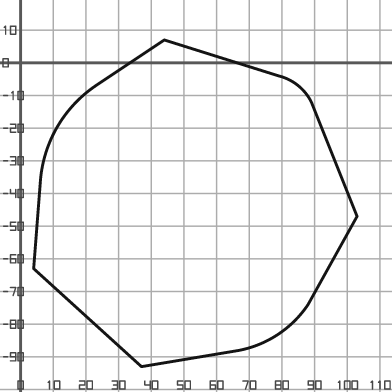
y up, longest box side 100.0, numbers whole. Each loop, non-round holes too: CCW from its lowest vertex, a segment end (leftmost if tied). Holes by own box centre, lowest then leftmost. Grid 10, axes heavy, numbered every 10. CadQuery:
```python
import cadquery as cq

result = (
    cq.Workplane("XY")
    .moveTo(37.0, -93.0)
    .lineTo(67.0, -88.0)
    .threePointArc((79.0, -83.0), (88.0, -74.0))
    .lineTo(103.0, -47.0)
    .lineTo(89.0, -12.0)
    .threePointArc((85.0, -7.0), (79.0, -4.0))
    .lineTo(44.0, 7.0)
    .lineTo(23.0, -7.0)
    .threePointArc((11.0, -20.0), (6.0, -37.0))
    .lineTo(4.0, -63.0)
    .close()
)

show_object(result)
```